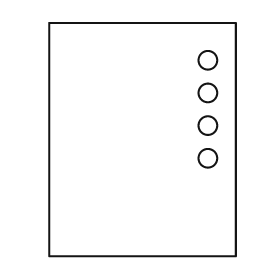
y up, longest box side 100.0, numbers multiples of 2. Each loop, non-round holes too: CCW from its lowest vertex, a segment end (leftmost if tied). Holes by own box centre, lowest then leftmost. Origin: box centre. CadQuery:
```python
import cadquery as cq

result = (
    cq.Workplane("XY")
    .moveTo(-40.0, -50.0)
    .lineTo(40.0, -50.0)
    .lineTo(40.0, 50.0)
    .lineTo(-40.0, 50.0)
    .close()
    .moveTo(28.0, -8.0)
    .circle(4.0)
    .moveTo(28.0, 6.0)
    .circle(4.0)
    .moveTo(28.0, 20.0)
    .circle(4.0)
    .moveTo(28.0, 34.0)
    .circle(4.0)
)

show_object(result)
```